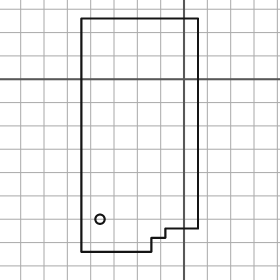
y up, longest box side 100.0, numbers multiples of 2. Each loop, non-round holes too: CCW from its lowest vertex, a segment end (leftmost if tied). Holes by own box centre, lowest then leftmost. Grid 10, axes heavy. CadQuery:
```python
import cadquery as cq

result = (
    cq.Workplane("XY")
    .moveTo(-44.0, -74.0)
    .lineTo(-14.0, -74.0)
    .lineTo(-14.0, -68.0)
    .lineTo(-8.0, -68.0)
    .lineTo(-8.0, -64.0)
    .lineTo(6.0, -64.0)
    .lineTo(6.0, 26.0)
    .lineTo(-44.0, 26.0)
    .close()
    .moveTo(-36.0, -60.0)
    .circle(2.0)
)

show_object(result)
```